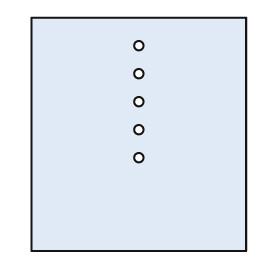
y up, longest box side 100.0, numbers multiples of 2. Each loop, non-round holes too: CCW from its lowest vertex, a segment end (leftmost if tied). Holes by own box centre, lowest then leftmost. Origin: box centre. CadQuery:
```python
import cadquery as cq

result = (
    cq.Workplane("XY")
    .moveTo(-46.0, -50.0)
    .lineTo(46.0, -50.0)
    .lineTo(46.0, 50.0)
    .lineTo(-46.0, 50.0)
    .close()
    .moveTo(0.0, -10.0)
    .circle(2.0)
    .moveTo(0.0, 2.0)
    .circle(2.0)
    .moveTo(0.0, 14.0)
    .circle(2.0)
    .moveTo(0.0, 26.0)
    .circle(2.0)
    .moveTo(0.0, 38.0)
    .circle(2.0)
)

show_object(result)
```